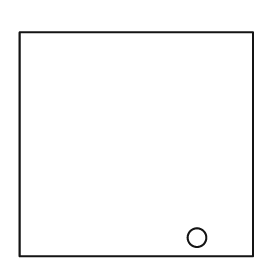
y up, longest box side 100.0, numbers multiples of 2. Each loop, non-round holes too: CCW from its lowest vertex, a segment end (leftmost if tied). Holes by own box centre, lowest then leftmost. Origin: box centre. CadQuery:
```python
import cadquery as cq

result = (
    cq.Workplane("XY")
    .moveTo(-50.0, -48.0)
    .lineTo(50.0, -48.0)
    .lineTo(50.0, 48.0)
    .lineTo(-50.0, 48.0)
    .close()
    .moveTo(26.0, -40.0)
    .circle(4.0)
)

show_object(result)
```